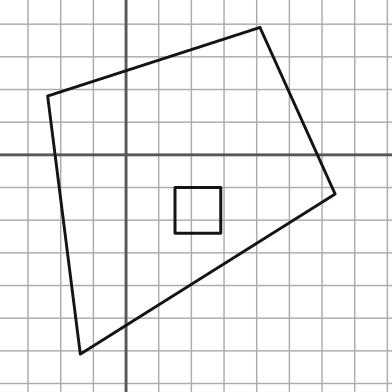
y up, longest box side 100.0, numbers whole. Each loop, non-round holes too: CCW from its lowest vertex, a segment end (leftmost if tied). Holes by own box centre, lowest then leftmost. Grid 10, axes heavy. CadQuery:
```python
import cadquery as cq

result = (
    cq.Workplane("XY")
    .moveTo(-14.0, -61.0)
    .lineTo(64.0, -12.0)
    .lineTo(41.0, 39.0)
    .lineTo(-24.0, 18.0)
    .close()
    .moveTo(15.0, -24.0)
    .lineTo(29.0, -24.0)
    .lineTo(29.0, -10.0)
    .lineTo(15.0, -10.0)
    .close()
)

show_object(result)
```